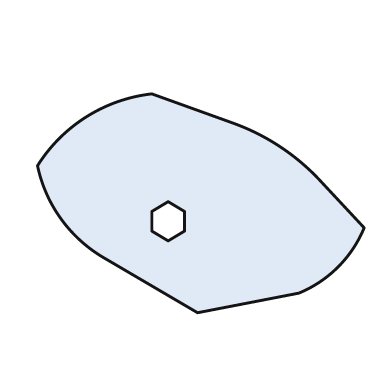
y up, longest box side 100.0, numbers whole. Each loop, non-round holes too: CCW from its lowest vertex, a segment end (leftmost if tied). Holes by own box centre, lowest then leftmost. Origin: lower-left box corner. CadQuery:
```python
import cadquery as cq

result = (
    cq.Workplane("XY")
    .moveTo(49.0, 0.0)
    .lineTo(80.0, 6.0)
    .threePointArc((92.0, 14.0), (100.0, 26.0))
    .lineTo(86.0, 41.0)
    .threePointArc((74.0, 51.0), (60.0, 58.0))
    .lineTo(35.0, 67.0)
    .threePointArc((15.0, 60.0), (0.0, 45.0))
    .threePointArc((7.0, 29.0), (20.0, 17.0))
    .close()
    .moveTo(40.0, 22.0)
    .lineTo(45.0, 25.0)
    .lineTo(45.0, 31.0)
    .lineTo(40.0, 34.0)
    .lineTo(35.0, 31.0)
    .lineTo(35.0, 25.0)
    .close()
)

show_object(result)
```